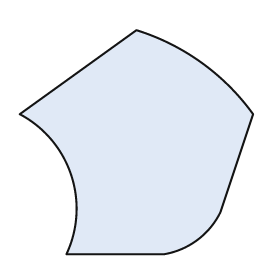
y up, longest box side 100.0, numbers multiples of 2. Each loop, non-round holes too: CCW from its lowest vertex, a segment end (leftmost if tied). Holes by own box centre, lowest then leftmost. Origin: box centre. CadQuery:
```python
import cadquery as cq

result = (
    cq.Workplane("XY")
    .moveTo(-30.0, -48.0)
    .lineTo(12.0, -48.0)
    .threePointArc((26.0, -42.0), (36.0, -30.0))
    .lineTo(50.0, 12.0)
    .threePointArc((28.0, 34.0), (0.0, 48.0))
    .lineTo(-50.0, 12.0)
    .threePointArc((-28.0, -14.0), (-30.0, -48.0))
    .close()
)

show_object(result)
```